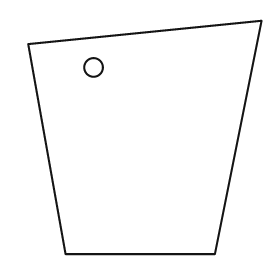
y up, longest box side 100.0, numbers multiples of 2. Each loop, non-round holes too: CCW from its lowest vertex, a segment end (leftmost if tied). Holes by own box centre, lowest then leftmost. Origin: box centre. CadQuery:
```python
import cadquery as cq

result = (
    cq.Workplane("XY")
    .moveTo(-34.0, -50.0)
    .lineTo(30.0, -50.0)
    .lineTo(50.0, 50.0)
    .lineTo(-50.0, 40.0)
    .close()
    .moveTo(-22.0, 30.0)
    .circle(4.0)
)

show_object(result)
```